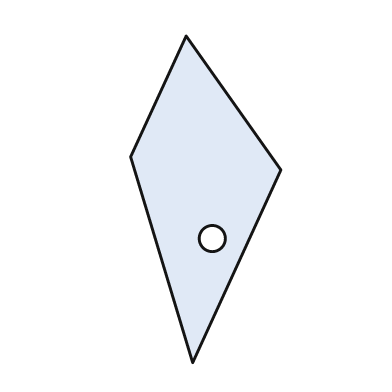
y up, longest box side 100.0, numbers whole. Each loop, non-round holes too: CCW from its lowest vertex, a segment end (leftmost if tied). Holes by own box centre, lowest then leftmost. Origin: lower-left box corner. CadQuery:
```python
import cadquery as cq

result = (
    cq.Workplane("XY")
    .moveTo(19.0, 0.0)
    .lineTo(46.0, 59.0)
    .lineTo(17.0, 100.0)
    .lineTo(0.0, 63.0)
    .close()
    .moveTo(25.0, 38.0)
    .circle(4.0)
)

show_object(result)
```